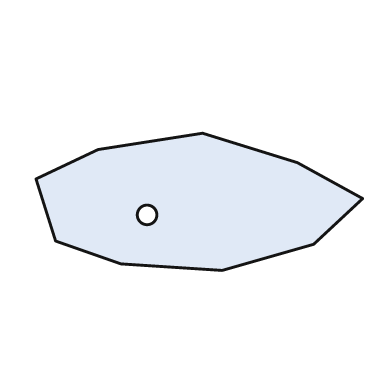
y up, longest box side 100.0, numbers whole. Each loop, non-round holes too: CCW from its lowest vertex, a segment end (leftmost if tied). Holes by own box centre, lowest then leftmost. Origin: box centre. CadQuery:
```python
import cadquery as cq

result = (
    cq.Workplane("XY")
    .moveTo(7.0, -21.0)
    .lineTo(35.0, -13.0)
    .lineTo(50.0, 1.0)
    .lineTo(30.0, 12.0)
    .lineTo(1.0, 21.0)
    .lineTo(-31.0, 16.0)
    .lineTo(-50.0, 7.0)
    .lineTo(-44.0, -12.0)
    .lineTo(-24.0, -19.0)
    .close()
    .moveTo(-16.0, -4.0)
    .circle(3.0)
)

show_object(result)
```